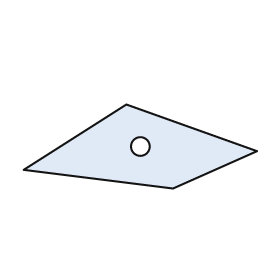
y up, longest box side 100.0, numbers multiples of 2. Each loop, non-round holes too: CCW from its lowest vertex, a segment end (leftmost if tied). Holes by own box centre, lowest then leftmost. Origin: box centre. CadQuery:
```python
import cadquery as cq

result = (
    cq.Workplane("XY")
    .moveTo(14.0, -18.0)
    .lineTo(50.0, -2.0)
    .lineTo(-6.0, 18.0)
    .lineTo(-50.0, -10.0)
    .close()
    .moveTo(0.0, 0.0)
    .circle(4.0)
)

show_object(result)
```